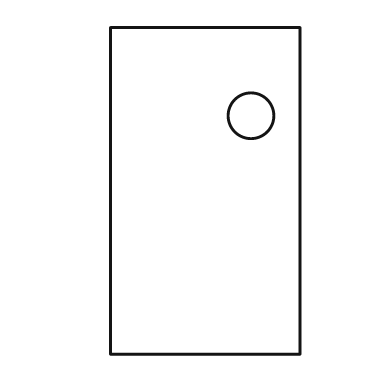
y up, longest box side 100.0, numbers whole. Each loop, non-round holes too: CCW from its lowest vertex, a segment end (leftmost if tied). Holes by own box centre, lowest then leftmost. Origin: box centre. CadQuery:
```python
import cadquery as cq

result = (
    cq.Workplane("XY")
    .moveTo(-29.0, -50.0)
    .lineTo(29.0, -50.0)
    .lineTo(29.0, 50.0)
    .lineTo(-29.0, 50.0)
    .close()
    .moveTo(14.0, 23.0)
    .circle(7.0)
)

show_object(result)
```